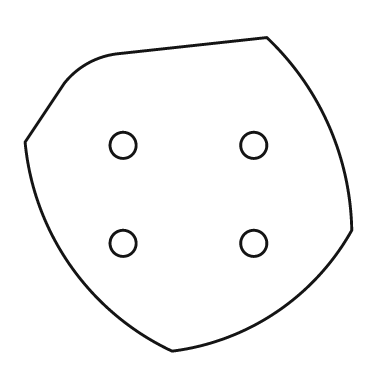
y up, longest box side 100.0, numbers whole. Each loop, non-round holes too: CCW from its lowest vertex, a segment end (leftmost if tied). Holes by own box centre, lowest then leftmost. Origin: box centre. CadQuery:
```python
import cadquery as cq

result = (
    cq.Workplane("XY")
    .moveTo(-5.0, -48.0)
    .threePointArc((27.0, -36.0), (50.0, -11.0))
    .threePointArc((43.0, 21.0), (24.0, 48.0))
    .lineTo(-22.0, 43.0)
    .threePointArc((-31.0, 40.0), (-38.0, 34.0))
    .lineTo(-50.0, 16.0)
    .threePointArc((-36.0, -22.0), (-5.0, -48.0))
    .close()
    .moveTo(-20.0, -15.0)
    .circle(4.0)
    .moveTo(20.0, -15.0)
    .circle(4.0)
    .moveTo(-20.0, 15.0)
    .circle(4.0)
    .moveTo(20.0, 15.0)
    .circle(4.0)
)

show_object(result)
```